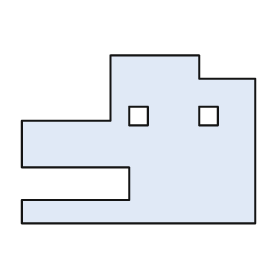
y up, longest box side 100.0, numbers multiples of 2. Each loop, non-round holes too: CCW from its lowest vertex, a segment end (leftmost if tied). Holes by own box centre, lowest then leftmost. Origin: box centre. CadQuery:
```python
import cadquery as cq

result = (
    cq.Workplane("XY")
    .moveTo(-50.0, -36.0)
    .lineTo(50.0, -36.0)
    .lineTo(50.0, 26.0)
    .lineTo(26.0, 26.0)
    .lineTo(26.0, 36.0)
    .lineTo(-12.0, 36.0)
    .lineTo(-12.0, 8.0)
    .lineTo(-50.0, 8.0)
    .lineTo(-50.0, -12.0)
    .lineTo(-4.0, -12.0)
    .lineTo(-4.0, -26.0)
    .lineTo(-50.0, -26.0)
    .close()
    .moveTo(-4.0, 6.0)
    .lineTo(4.0, 6.0)
    .lineTo(4.0, 14.0)
    .lineTo(-4.0, 14.0)
    .close()
    .moveTo(26.0, 6.0)
    .lineTo(34.0, 6.0)
    .lineTo(34.0, 14.0)
    .lineTo(26.0, 14.0)
    .close()
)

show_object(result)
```